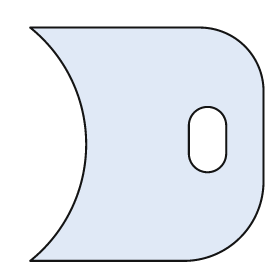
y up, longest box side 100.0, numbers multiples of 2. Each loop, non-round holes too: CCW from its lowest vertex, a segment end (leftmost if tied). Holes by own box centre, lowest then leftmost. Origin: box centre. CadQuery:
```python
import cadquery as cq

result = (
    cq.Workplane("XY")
    .moveTo(-50.0, -50.0)
    .lineTo(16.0, -50.0)
    .threePointArc((40.0, -40.0), (50.0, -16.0))
    .lineTo(50.0, 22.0)
    .threePointArc((42.0, 42.0), (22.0, 50.0))
    .lineTo(-50.0, 50.0)
    .threePointArc((-26.0, 0.0), (-50.0, -50.0))
    .close()
    .moveTo(18.0, -4.0)
    .threePointArc((26.0, -12.0), (34.0, -4.0))
    .lineTo(34.0, 8.0)
    .threePointArc((26.0, 16.0), (18.0, 8.0))
    .close()
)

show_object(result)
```